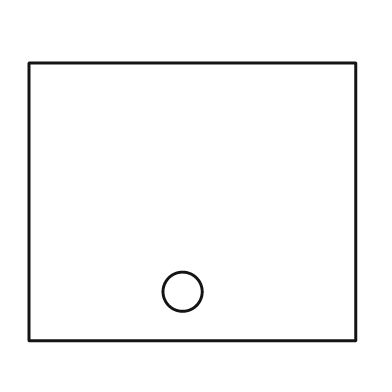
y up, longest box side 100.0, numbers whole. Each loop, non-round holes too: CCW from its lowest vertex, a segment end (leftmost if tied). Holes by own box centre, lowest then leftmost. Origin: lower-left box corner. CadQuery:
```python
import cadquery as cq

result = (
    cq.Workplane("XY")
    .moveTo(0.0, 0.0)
    .lineTo(100.0, 0.0)
    .lineTo(100.0, 85.0)
    .lineTo(0.0, 85.0)
    .close()
    .moveTo(47.0, 15.0)
    .circle(6.0)
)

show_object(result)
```